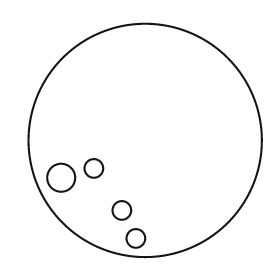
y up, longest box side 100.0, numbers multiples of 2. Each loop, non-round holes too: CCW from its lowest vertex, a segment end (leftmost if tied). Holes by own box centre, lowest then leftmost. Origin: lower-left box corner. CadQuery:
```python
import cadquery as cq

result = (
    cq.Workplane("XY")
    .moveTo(50.0, 50.0)
    .circle(50.0)
    .moveTo(46.0, 8.0)
    .circle(4.0)
    .moveTo(40.0, 20.0)
    .circle(4.0)
    .moveTo(14.0, 34.0)
    .circle(6.0)
    .moveTo(28.0, 38.0)
    .circle(4.0)
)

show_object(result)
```